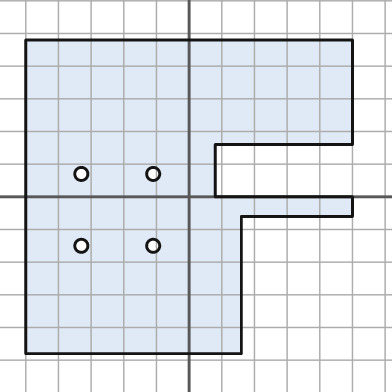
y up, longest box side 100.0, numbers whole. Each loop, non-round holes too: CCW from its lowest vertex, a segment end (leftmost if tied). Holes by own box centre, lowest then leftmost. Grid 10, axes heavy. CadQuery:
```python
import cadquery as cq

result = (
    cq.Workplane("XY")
    .moveTo(-50.0, -48.0)
    .lineTo(16.0, -48.0)
    .lineTo(16.0, -6.0)
    .lineTo(50.0, -6.0)
    .lineTo(50.0, 0.0)
    .lineTo(8.0, 0.0)
    .lineTo(8.0, 16.0)
    .lineTo(50.0, 16.0)
    .lineTo(50.0, 48.0)
    .lineTo(-50.0, 48.0)
    .close()
    .moveTo(-33.0, -15.0)
    .circle(2.0)
    .moveTo(-11.0, -15.0)
    .circle(2.0)
    .moveTo(-33.0, 7.0)
    .circle(2.0)
    .moveTo(-11.0, 7.0)
    .circle(2.0)
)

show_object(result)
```